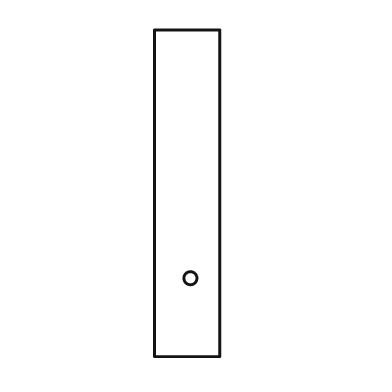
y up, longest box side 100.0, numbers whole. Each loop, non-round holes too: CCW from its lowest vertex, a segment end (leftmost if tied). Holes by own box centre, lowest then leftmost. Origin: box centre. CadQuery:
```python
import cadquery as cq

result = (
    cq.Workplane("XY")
    .moveTo(-10.0, -50.0)
    .lineTo(10.0, -50.0)
    .lineTo(10.0, 50.0)
    .lineTo(-10.0, 50.0)
    .close()
    .moveTo(1.0, -26.0)
    .circle(2.0)
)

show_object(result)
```